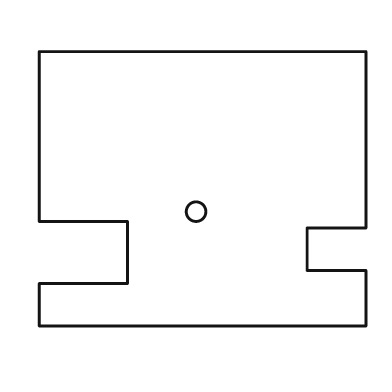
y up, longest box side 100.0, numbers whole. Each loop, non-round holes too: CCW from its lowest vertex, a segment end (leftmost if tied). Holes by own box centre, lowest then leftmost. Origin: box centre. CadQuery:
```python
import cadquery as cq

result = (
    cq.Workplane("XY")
    .moveTo(-50.0, -42.0)
    .lineTo(50.0, -42.0)
    .lineTo(50.0, -25.0)
    .lineTo(32.0, -25.0)
    .lineTo(32.0, -12.0)
    .lineTo(50.0, -12.0)
    .lineTo(50.0, 42.0)
    .lineTo(-50.0, 42.0)
    .lineTo(-50.0, -10.0)
    .lineTo(-23.0, -10.0)
    .lineTo(-23.0, -29.0)
    .lineTo(-50.0, -29.0)
    .close()
    .moveTo(-2.0, -7.0)
    .circle(3.0)
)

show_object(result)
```